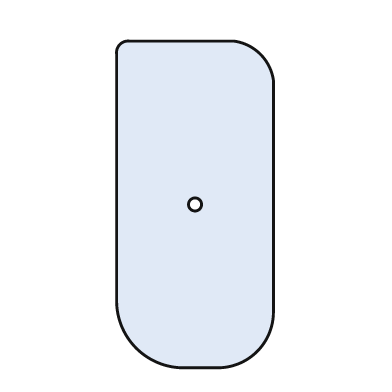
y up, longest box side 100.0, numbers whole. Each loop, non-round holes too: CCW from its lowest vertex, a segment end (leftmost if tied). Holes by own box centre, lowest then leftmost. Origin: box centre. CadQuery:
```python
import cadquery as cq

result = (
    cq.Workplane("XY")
    .moveTo(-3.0, -50.0)
    .lineTo(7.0, -50.0)
    .threePointArc((19.0, -45.0), (24.0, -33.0))
    .lineTo(24.0, 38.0)
    .threePointArc((20.0, 46.0), (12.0, 50.0))
    .lineTo(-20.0, 50.0)
    .threePointArc((-23.0, 49.0), (-24.0, 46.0))
    .lineTo(-24.0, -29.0)
    .threePointArc((-18.0, -44.0), (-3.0, -50.0))
    .close()
    .moveTo(0.0, 0.0)
    .circle(2.0)
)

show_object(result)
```